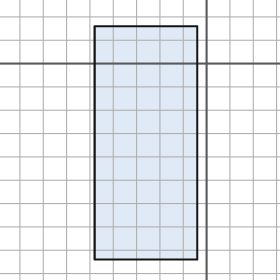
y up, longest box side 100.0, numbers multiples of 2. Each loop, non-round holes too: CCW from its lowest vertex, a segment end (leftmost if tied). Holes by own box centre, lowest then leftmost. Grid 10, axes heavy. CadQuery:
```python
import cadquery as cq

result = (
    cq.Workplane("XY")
    .moveTo(-48.0, -84.0)
    .lineTo(-4.0, -84.0)
    .lineTo(-4.0, 16.0)
    .lineTo(-48.0, 16.0)
    .close()
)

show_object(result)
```